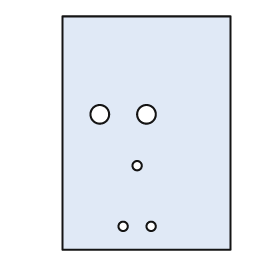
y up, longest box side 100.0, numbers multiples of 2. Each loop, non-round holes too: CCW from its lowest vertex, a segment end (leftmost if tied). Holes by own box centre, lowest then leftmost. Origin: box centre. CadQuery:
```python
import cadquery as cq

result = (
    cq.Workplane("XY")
    .moveTo(-36.0, -50.0)
    .lineTo(36.0, -50.0)
    .lineTo(36.0, 50.0)
    .lineTo(-36.0, 50.0)
    .close()
    .moveTo(-10.0, -40.0)
    .circle(2.0)
    .moveTo(2.0, -40.0)
    .circle(2.0)
    .moveTo(-4.0, -14.0)
    .circle(2.0)
    .moveTo(-20.0, 8.0)
    .circle(4.0)
    .moveTo(0.0, 8.0)
    .circle(4.0)
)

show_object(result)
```